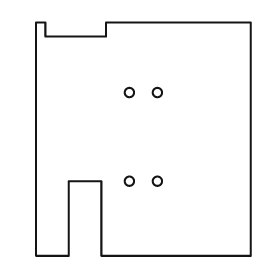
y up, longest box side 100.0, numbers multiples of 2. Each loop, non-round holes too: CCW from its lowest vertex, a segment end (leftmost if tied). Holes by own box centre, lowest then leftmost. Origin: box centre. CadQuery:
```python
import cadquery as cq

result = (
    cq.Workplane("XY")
    .moveTo(-46.0, -50.0)
    .lineTo(-32.0, -50.0)
    .lineTo(-32.0, -18.0)
    .lineTo(-18.0, -18.0)
    .lineTo(-18.0, -50.0)
    .lineTo(46.0, -50.0)
    .lineTo(46.0, 50.0)
    .lineTo(-16.0, 50.0)
    .lineTo(-16.0, 44.0)
    .lineTo(-42.0, 44.0)
    .lineTo(-42.0, 50.0)
    .lineTo(-46.0, 50.0)
    .close()
    .moveTo(-6.0, -18.0)
    .circle(2.0)
    .moveTo(6.0, -18.0)
    .circle(2.0)
    .moveTo(-6.0, 20.0)
    .circle(2.0)
    .moveTo(6.0, 20.0)
    .circle(2.0)
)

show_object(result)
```